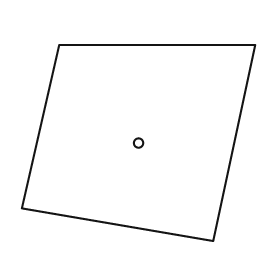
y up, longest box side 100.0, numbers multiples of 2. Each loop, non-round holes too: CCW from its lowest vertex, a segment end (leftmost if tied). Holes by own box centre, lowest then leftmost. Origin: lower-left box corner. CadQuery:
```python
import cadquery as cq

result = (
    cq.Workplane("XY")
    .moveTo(82.0, 0.0)
    .lineTo(100.0, 84.0)
    .lineTo(16.0, 84.0)
    .lineTo(0.0, 14.0)
    .close()
    .moveTo(50.0, 42.0)
    .circle(2.0)
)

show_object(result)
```